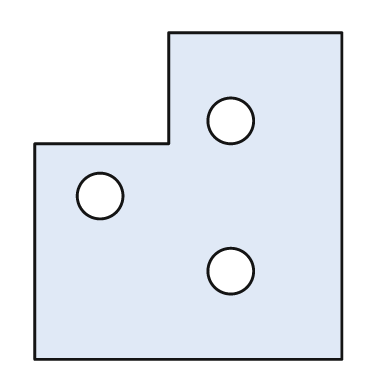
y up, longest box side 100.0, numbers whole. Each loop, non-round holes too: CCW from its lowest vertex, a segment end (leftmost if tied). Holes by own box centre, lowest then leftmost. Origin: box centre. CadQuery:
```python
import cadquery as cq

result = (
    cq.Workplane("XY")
    .moveTo(-47.0, -50.0)
    .lineTo(47.0, -50.0)
    .lineTo(47.0, 50.0)
    .lineTo(-6.0, 50.0)
    .lineTo(-6.0, 16.0)
    .lineTo(-47.0, 16.0)
    .close()
    .moveTo(13.0, -23.0)
    .circle(7.0)
    .moveTo(-27.0, 0.0)
    .circle(7.0)
    .moveTo(13.0, 23.0)
    .circle(7.0)
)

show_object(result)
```